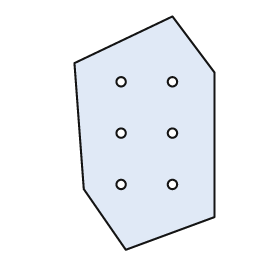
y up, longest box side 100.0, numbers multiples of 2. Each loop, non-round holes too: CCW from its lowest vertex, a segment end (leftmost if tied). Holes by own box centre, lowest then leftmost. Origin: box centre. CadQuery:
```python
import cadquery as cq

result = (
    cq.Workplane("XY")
    .moveTo(-8.0, -50.0)
    .lineTo(30.0, -36.0)
    .lineTo(30.0, 26.0)
    .lineTo(12.0, 50.0)
    .lineTo(-30.0, 30.0)
    .lineTo(-26.0, -24.0)
    .close()
    .moveTo(-10.0, -22.0)
    .circle(2.0)
    .moveTo(12.0, -22.0)
    .circle(2.0)
    .moveTo(-10.0, 0.0)
    .circle(2.0)
    .moveTo(12.0, 0.0)
    .circle(2.0)
    .moveTo(-10.0, 22.0)
    .circle(2.0)
    .moveTo(12.0, 22.0)
    .circle(2.0)
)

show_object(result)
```